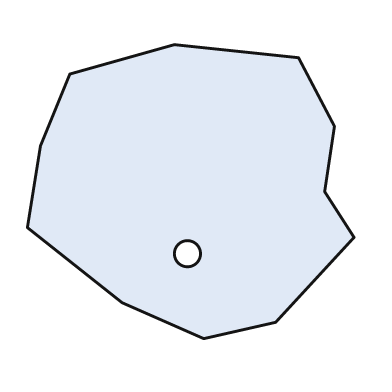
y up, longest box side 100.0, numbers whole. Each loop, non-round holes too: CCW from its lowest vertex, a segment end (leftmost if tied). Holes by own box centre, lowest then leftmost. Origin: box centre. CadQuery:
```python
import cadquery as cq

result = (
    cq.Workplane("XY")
    .moveTo(4.0, -45.0)
    .lineTo(26.0, -40.0)
    .lineTo(50.0, -14.0)
    .lineTo(41.0, 0.0)
    .lineTo(44.0, 20.0)
    .lineTo(33.0, 41.0)
    .lineTo(-5.0, 45.0)
    .lineTo(-37.0, 36.0)
    .lineTo(-46.0, 14.0)
    .lineTo(-50.0, -11.0)
    .lineTo(-21.0, -34.0)
    .close()
    .moveTo(-1.0, -19.0)
    .circle(4.0)
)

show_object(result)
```